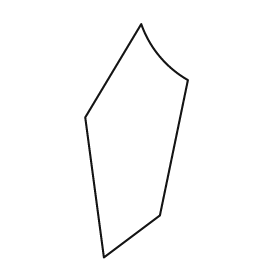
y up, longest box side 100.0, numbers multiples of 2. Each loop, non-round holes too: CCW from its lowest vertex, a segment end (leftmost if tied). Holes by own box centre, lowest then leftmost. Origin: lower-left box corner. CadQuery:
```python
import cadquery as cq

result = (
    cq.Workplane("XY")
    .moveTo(8.0, 0.0)
    .lineTo(32.0, 18.0)
    .lineTo(44.0, 76.0)
    .threePointArc((32.0, 86.0), (24.0, 100.0))
    .lineTo(0.0, 60.0)
    .close()
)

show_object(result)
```